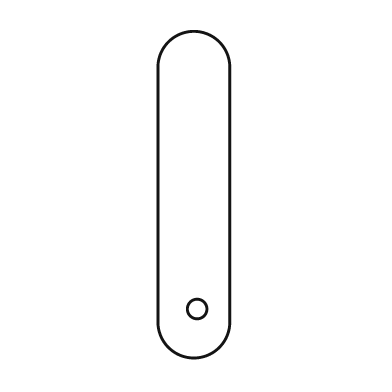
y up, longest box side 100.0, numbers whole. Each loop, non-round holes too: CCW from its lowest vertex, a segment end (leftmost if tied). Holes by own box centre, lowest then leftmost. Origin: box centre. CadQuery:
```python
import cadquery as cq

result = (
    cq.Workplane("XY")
    .moveTo(-11.0, -39.0)
    .threePointArc((0.0, -50.0), (11.0, -39.0))
    .lineTo(11.0, 39.0)
    .threePointArc((0.0, 50.0), (-11.0, 39.0))
    .close()
    .moveTo(1.0, -35.0)
    .circle(3.0)
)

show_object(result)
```